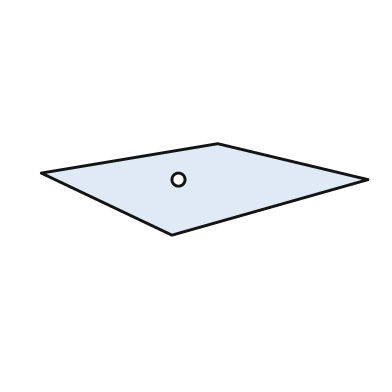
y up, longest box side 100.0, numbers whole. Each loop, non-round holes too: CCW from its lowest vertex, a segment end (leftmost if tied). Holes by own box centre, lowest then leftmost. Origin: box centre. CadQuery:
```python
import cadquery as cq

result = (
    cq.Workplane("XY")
    .moveTo(-10.0, -14.0)
    .lineTo(50.0, 3.0)
    .lineTo(4.0, 14.0)
    .lineTo(-50.0, 5.0)
    .close()
    .moveTo(-8.0, 3.0)
    .circle(2.0)
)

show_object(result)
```